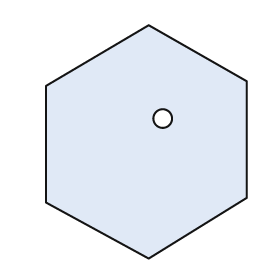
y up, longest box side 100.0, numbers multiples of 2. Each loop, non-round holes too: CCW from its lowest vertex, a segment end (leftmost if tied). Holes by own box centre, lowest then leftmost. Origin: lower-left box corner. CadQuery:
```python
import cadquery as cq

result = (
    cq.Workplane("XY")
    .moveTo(44.0, 0.0)
    .lineTo(86.0, 26.0)
    .lineTo(86.0, 76.0)
    .lineTo(44.0, 100.0)
    .lineTo(0.0, 74.0)
    .lineTo(0.0, 24.0)
    .close()
    .moveTo(50.0, 60.0)
    .circle(4.0)
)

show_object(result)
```